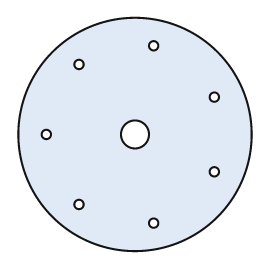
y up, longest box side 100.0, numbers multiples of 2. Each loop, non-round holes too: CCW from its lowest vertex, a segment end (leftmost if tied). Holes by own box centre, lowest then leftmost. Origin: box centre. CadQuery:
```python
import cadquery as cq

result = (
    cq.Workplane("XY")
    .moveTo(0.0, 0.0)
    .circle(50.0)
    .moveTo(8.0, -38.0)
    .circle(2.0)
    .moveTo(-24.0, -30.0)
    .circle(2.0)
    .moveTo(34.0, -16.0)
    .circle(2.0)
    .moveTo(-38.0, 0.0)
    .circle(2.0)
    .moveTo(0.0, 0.0)
    .circle(6.0)
    .moveTo(34.0, 16.0)
    .circle(2.0)
    .moveTo(-24.0, 30.0)
    .circle(2.0)
    .moveTo(8.0, 38.0)
    .circle(2.0)
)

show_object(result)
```